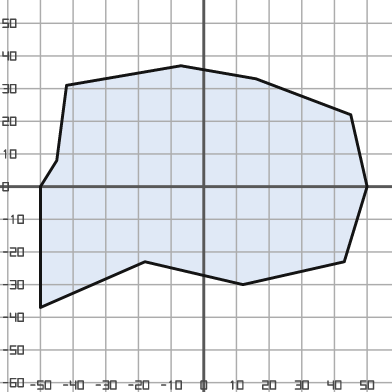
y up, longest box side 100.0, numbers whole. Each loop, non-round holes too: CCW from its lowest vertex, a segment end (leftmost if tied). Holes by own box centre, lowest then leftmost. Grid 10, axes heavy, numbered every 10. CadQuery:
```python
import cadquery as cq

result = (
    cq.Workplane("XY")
    .moveTo(-50.0, -37.0)
    .lineTo(-18.0, -23.0)
    .lineTo(12.0, -30.0)
    .lineTo(43.0, -23.0)
    .lineTo(50.0, 0.0)
    .lineTo(45.0, 22.0)
    .lineTo(16.0, 33.0)
    .lineTo(-7.0, 37.0)
    .lineTo(-42.0, 31.0)
    .lineTo(-45.0, 8.0)
    .lineTo(-50.0, 0.0)
    .close()
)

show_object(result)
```